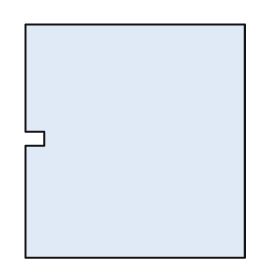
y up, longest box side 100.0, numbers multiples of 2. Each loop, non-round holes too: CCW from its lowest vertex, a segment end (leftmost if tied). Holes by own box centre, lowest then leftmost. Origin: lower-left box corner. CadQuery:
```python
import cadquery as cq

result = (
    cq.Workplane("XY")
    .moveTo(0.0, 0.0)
    .lineTo(94.0, 0.0)
    .lineTo(94.0, 100.0)
    .lineTo(0.0, 100.0)
    .lineTo(0.0, 54.0)
    .lineTo(8.0, 54.0)
    .lineTo(8.0, 48.0)
    .lineTo(0.0, 48.0)
    .close()
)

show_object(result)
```